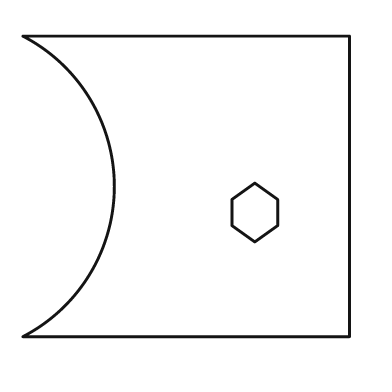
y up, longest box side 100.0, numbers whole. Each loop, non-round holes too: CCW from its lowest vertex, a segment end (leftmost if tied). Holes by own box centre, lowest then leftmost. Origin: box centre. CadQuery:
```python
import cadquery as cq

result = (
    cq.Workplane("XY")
    .moveTo(-50.0, -46.0)
    .lineTo(50.0, -46.0)
    .lineTo(50.0, 46.0)
    .lineTo(-50.0, 46.0)
    .threePointArc((-22.0, 0.0), (-50.0, -46.0))
    .close()
    .moveTo(21.0, -17.0)
    .lineTo(28.0, -12.0)
    .lineTo(28.0, -4.0)
    .lineTo(21.0, 1.0)
    .lineTo(14.0, -4.0)
    .lineTo(14.0, -12.0)
    .close()
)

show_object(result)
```